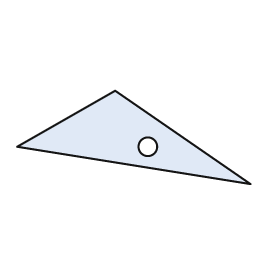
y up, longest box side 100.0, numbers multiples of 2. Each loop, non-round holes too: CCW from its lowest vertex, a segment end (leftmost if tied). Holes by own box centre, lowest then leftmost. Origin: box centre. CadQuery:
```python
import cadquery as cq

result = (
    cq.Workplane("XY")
    .moveTo(50.0, -20.0)
    .lineTo(-8.0, 20.0)
    .lineTo(-50.0, -4.0)
    .close()
    .moveTo(6.0, -4.0)
    .circle(4.0)
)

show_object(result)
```